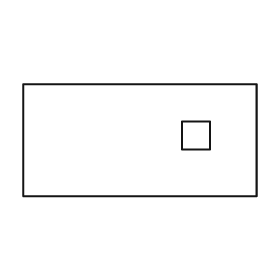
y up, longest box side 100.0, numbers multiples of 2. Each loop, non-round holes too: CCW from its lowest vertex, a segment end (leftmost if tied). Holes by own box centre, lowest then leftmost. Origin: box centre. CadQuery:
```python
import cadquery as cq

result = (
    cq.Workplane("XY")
    .moveTo(-50.0, -24.0)
    .lineTo(50.0, -24.0)
    .lineTo(50.0, 24.0)
    .lineTo(-50.0, 24.0)
    .close()
    .moveTo(18.0, -4.0)
    .lineTo(30.0, -4.0)
    .lineTo(30.0, 8.0)
    .lineTo(18.0, 8.0)
    .close()
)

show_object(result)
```